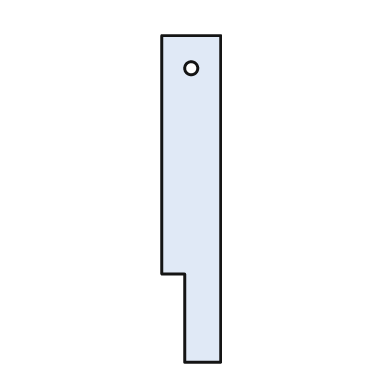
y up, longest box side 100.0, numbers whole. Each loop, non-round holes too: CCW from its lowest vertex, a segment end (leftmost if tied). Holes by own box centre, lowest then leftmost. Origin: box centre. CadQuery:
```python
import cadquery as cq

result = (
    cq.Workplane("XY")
    .moveTo(-2.0, -50.0)
    .lineTo(9.0, -50.0)
    .lineTo(9.0, 50.0)
    .lineTo(-9.0, 50.0)
    .lineTo(-9.0, -23.0)
    .lineTo(-2.0, -23.0)
    .close()
    .moveTo(0.0, 40.0)
    .circle(2.0)
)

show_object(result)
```